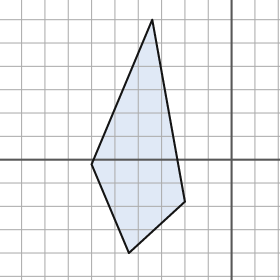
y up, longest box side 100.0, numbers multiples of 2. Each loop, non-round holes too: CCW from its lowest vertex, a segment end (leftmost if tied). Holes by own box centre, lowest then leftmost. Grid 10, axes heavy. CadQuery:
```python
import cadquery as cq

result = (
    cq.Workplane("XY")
    .moveTo(-44.0, -40.0)
    .lineTo(-20.0, -18.0)
    .lineTo(-34.0, 60.0)
    .lineTo(-60.0, -2.0)
    .close()
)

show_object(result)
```